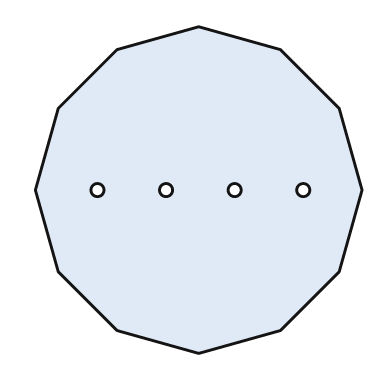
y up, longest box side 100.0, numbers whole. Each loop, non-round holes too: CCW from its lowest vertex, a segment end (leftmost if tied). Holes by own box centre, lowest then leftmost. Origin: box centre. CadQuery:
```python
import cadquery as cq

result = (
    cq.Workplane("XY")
    .moveTo(0.0, -50.0)
    .lineTo(25.0, -43.0)
    .lineTo(43.0, -25.0)
    .lineTo(50.0, 0.0)
    .lineTo(43.0, 25.0)
    .lineTo(25.0, 43.0)
    .lineTo(0.0, 50.0)
    .lineTo(-25.0, 43.0)
    .lineTo(-43.0, 25.0)
    .lineTo(-50.0, 0.0)
    .lineTo(-43.0, -25.0)
    .lineTo(-25.0, -43.0)
    .close()
    .moveTo(-31.0, 0.0)
    .circle(2.0)
    .moveTo(-10.0, 0.0)
    .circle(2.0)
    .moveTo(11.0, 0.0)
    .circle(2.0)
    .moveTo(32.0, 0.0)
    .circle(2.0)
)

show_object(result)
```